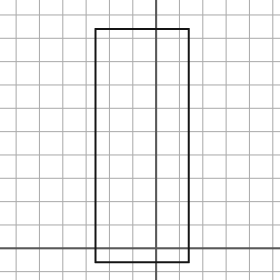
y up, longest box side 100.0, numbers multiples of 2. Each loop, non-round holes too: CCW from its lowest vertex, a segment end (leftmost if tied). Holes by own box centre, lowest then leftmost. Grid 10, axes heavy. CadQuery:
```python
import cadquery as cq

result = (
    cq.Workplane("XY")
    .moveTo(-26.0, -6.0)
    .lineTo(14.0, -6.0)
    .lineTo(14.0, 94.0)
    .lineTo(-26.0, 94.0)
    .close()
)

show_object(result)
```